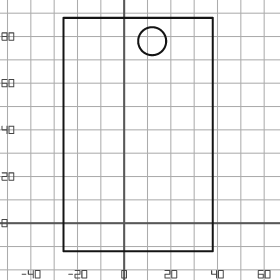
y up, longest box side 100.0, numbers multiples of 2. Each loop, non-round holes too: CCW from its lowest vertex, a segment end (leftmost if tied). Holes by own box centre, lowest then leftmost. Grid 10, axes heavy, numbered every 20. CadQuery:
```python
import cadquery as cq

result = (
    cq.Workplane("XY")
    .moveTo(-26.0, -12.0)
    .lineTo(38.0, -12.0)
    .lineTo(38.0, 88.0)
    .lineTo(-26.0, 88.0)
    .close()
    .moveTo(12.0, 78.0)
    .circle(6.0)
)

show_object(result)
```